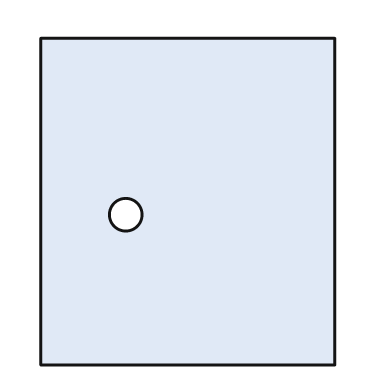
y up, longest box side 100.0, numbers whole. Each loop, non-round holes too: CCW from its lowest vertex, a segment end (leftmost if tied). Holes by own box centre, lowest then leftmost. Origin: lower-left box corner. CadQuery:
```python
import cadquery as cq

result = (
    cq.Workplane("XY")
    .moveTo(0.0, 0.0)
    .lineTo(90.0, 0.0)
    .lineTo(90.0, 100.0)
    .lineTo(0.0, 100.0)
    .close()
    .moveTo(26.0, 46.0)
    .circle(5.0)
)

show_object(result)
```